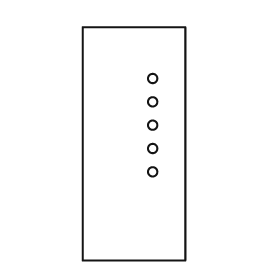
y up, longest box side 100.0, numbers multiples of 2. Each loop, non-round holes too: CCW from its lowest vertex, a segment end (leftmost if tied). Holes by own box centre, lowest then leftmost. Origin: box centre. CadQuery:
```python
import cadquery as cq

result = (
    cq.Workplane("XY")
    .moveTo(-22.0, -50.0)
    .lineTo(22.0, -50.0)
    .lineTo(22.0, 50.0)
    .lineTo(-22.0, 50.0)
    .close()
    .moveTo(8.0, -12.0)
    .circle(2.0)
    .moveTo(8.0, -2.0)
    .circle(2.0)
    .moveTo(8.0, 8.0)
    .circle(2.0)
    .moveTo(8.0, 18.0)
    .circle(2.0)
    .moveTo(8.0, 28.0)
    .circle(2.0)
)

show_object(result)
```